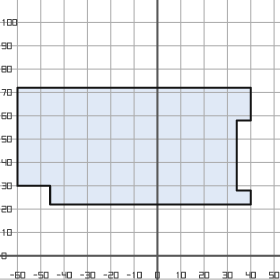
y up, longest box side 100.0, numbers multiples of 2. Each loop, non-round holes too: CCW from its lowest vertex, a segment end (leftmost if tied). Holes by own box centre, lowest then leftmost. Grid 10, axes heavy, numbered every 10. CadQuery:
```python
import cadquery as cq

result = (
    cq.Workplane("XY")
    .moveTo(-46.0, 22.0)
    .lineTo(40.0, 22.0)
    .lineTo(40.0, 28.0)
    .lineTo(34.0, 28.0)
    .lineTo(34.0, 58.0)
    .lineTo(40.0, 58.0)
    .lineTo(40.0, 72.0)
    .lineTo(-60.0, 72.0)
    .lineTo(-60.0, 30.0)
    .lineTo(-46.0, 30.0)
    .close()
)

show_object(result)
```